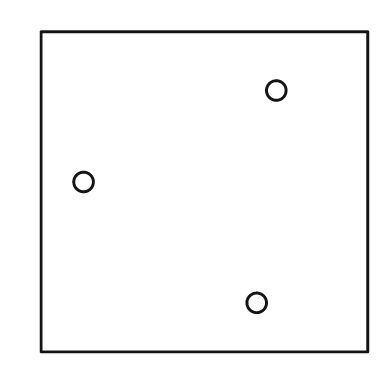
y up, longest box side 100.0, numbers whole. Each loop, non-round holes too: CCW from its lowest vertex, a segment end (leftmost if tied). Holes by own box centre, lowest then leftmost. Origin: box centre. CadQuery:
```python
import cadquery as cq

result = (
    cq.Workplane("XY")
    .moveTo(-50.0, -49.0)
    .lineTo(50.0, -49.0)
    .lineTo(50.0, 49.0)
    .lineTo(-50.0, 49.0)
    .close()
    .moveTo(16.0, -34.0)
    .circle(3.0)
    .moveTo(-37.0, 3.0)
    .circle(3.0)
    .moveTo(22.0, 31.0)
    .circle(3.0)
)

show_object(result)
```